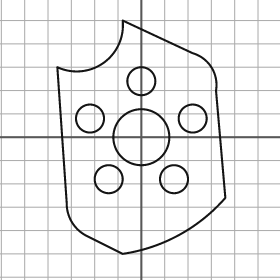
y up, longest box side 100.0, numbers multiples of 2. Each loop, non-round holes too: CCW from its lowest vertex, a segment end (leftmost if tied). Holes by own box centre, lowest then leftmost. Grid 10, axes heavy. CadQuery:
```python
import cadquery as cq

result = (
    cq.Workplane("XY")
    .moveTo(-8.0, -50.0)
    .threePointArc((16.0, -42.0), (36.0, -26.0))
    .lineTo(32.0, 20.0)
    .threePointArc((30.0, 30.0), (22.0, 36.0))
    .lineTo(-8.0, 50.0)
    .threePointArc((-16.0, 32.0), (-36.0, 30.0))
    .lineTo(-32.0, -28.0)
    .threePointArc((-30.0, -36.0), (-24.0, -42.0))
    .close()
    .moveTo(-14.0, -18.0)
    .circle(6.0)
    .moveTo(14.0, -18.0)
    .circle(6.0)
    .moveTo(0.0, 0.0)
    .circle(12.0)
    .moveTo(-22.0, 8.0)
    .circle(6.0)
    .moveTo(22.0, 8.0)
    .circle(6.0)
    .moveTo(0.0, 24.0)
    .circle(6.0)
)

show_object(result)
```